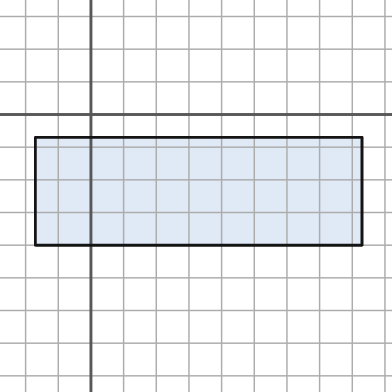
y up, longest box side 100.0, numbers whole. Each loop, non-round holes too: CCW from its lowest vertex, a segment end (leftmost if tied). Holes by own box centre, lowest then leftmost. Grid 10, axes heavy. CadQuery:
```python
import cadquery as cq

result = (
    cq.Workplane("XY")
    .moveTo(-17.0, -40.0)
    .lineTo(83.0, -40.0)
    .lineTo(83.0, -7.0)
    .lineTo(-17.0, -7.0)
    .close()
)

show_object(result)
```